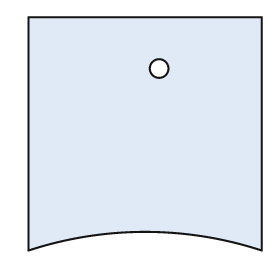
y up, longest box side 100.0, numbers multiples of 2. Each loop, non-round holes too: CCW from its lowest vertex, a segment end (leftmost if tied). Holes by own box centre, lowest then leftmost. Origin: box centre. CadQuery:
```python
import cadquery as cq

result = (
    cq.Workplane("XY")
    .moveTo(-50.0, -50.0)
    .threePointArc((0.0, -42.0), (50.0, -50.0))
    .lineTo(50.0, 50.0)
    .lineTo(-50.0, 50.0)
    .close()
    .moveTo(6.0, 28.0)
    .circle(4.0)
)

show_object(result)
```